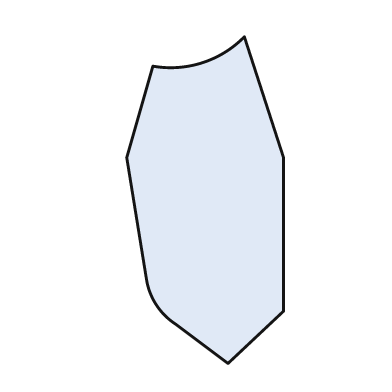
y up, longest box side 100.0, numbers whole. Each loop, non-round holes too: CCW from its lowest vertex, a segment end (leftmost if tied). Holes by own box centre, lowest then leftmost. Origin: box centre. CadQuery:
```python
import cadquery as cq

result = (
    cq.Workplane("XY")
    .moveTo(7.0, -50.0)
    .lineTo(24.0, -34.0)
    .lineTo(24.0, 13.0)
    .lineTo(12.0, 50.0)
    .threePointArc((-1.0, 42.0), (-16.0, 41.0))
    .lineTo(-24.0, 13.0)
    .lineTo(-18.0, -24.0)
    .threePointArc((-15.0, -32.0), (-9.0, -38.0))
    .close()
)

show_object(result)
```